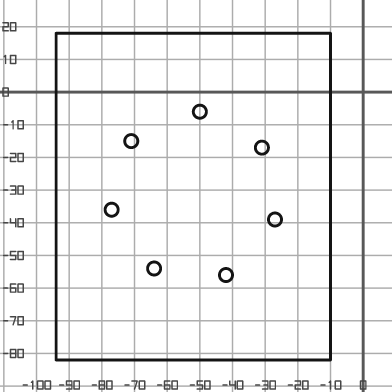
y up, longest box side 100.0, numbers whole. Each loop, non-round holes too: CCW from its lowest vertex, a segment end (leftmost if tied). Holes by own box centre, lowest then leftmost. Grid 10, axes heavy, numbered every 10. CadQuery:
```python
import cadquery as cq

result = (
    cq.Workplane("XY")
    .moveTo(-94.0, -82.0)
    .lineTo(-10.0, -82.0)
    .lineTo(-10.0, 18.0)
    .lineTo(-94.0, 18.0)
    .close()
    .moveTo(-42.0, -56.0)
    .circle(2.0)
    .moveTo(-64.0, -54.0)
    .circle(2.0)
    .moveTo(-27.0, -39.0)
    .circle(2.0)
    .moveTo(-77.0, -36.0)
    .circle(2.0)
    .moveTo(-31.0, -17.0)
    .circle(2.0)
    .moveTo(-71.0, -15.0)
    .circle(2.0)
    .moveTo(-50.0, -6.0)
    .circle(2.0)
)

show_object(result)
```